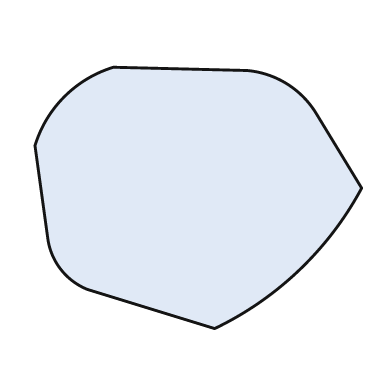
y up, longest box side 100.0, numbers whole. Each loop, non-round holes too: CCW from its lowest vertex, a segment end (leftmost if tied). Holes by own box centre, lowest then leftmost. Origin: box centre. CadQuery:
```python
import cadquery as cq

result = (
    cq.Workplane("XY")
    .moveTo(5.0, -40.0)
    .threePointArc((31.0, -22.0), (50.0, 3.0))
    .lineTo(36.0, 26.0)
    .threePointArc((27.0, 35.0), (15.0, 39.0))
    .lineTo(-26.0, 40.0)
    .threePointArc((-41.0, 31.0), (-50.0, 16.0))
    .lineTo(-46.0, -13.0)
    .threePointArc((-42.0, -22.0), (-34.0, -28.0))
    .close()
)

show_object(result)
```